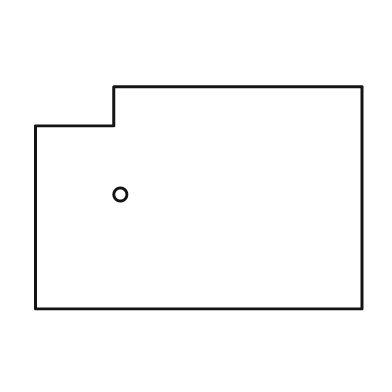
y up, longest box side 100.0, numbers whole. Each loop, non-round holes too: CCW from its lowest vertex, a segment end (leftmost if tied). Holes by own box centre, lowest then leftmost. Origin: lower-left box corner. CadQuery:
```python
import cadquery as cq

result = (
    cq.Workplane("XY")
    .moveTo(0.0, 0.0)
    .lineTo(100.0, 0.0)
    .lineTo(100.0, 68.0)
    .lineTo(24.0, 68.0)
    .lineTo(24.0, 56.0)
    .lineTo(0.0, 56.0)
    .close()
    .moveTo(26.0, 35.0)
    .circle(2.0)
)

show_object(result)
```